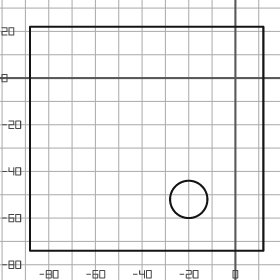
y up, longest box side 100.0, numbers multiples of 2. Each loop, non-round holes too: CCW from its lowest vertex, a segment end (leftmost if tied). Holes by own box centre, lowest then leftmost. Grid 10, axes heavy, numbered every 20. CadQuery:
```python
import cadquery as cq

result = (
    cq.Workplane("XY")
    .moveTo(-88.0, -74.0)
    .lineTo(12.0, -74.0)
    .lineTo(12.0, 22.0)
    .lineTo(-88.0, 22.0)
    .close()
    .moveTo(-20.0, -52.0)
    .circle(8.0)
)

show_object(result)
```